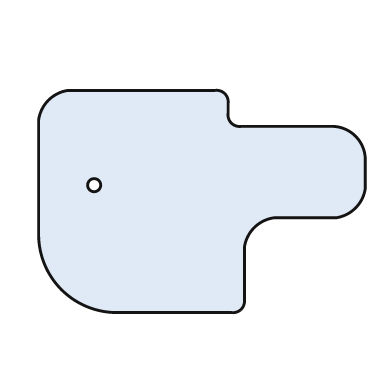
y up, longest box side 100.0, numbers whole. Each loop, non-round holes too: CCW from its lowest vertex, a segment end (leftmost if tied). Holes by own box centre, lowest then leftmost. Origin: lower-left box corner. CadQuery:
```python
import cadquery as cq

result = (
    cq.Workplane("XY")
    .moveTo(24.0, 0.0)
    .lineTo(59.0, 0.0)
    .threePointArc((62.0, 1.0), (63.0, 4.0))
    .lineTo(63.0, 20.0)
    .threePointArc((66.0, 26.0), (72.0, 29.0))
    .lineTo(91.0, 29.0)
    .threePointArc((97.0, 32.0), (100.0, 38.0))
    .lineTo(100.0, 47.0)
    .threePointArc((97.0, 54.0), (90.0, 57.0))
    .lineTo(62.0, 57.0)
    .threePointArc((59.0, 58.0), (58.0, 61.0))
    .lineTo(58.0, 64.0)
    .threePointArc((57.0, 67.0), (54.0, 68.0))
    .lineTo(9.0, 68.0)
    .threePointArc((3.0, 65.0), (0.0, 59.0))
    .lineTo(0.0, 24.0)
    .threePointArc((7.0, 7.0), (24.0, 0.0))
    .close()
    .moveTo(17.0, 39.0)
    .circle(2.0)
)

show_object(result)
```